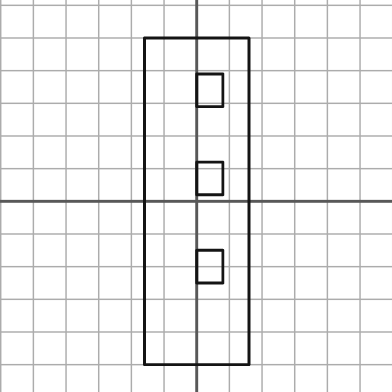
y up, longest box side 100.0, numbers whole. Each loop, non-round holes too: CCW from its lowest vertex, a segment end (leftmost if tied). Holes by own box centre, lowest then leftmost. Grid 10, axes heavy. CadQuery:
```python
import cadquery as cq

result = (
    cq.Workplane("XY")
    .moveTo(-16.0, -50.0)
    .lineTo(16.0, -50.0)
    .lineTo(16.0, 50.0)
    .lineTo(-16.0, 50.0)
    .close()
    .moveTo(0.0, -25.0)
    .lineTo(8.0, -25.0)
    .lineTo(8.0, -15.0)
    .lineTo(0.0, -15.0)
    .close()
    .moveTo(0.0, 2.0)
    .lineTo(8.0, 2.0)
    .lineTo(8.0, 12.0)
    .lineTo(0.0, 12.0)
    .close()
    .moveTo(0.0, 29.0)
    .lineTo(8.0, 29.0)
    .lineTo(8.0, 39.0)
    .lineTo(0.0, 39.0)
    .close()
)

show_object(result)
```